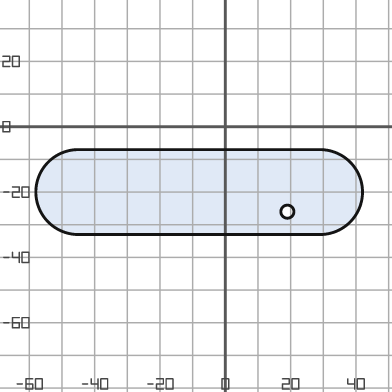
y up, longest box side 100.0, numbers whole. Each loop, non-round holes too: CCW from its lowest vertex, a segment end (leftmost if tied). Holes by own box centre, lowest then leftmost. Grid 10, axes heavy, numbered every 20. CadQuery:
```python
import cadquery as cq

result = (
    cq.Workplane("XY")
    .moveTo(-45.0, -33.0)
    .lineTo(29.0, -33.0)
    .threePointArc((42.0, -20.0), (29.0, -7.0))
    .lineTo(-45.0, -7.0)
    .threePointArc((-58.0, -20.0), (-45.0, -33.0))
    .close()
    .moveTo(19.0, -26.0)
    .circle(2.0)
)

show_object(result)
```